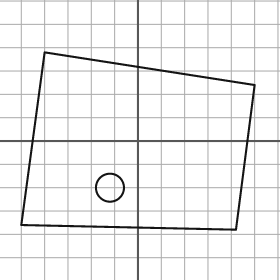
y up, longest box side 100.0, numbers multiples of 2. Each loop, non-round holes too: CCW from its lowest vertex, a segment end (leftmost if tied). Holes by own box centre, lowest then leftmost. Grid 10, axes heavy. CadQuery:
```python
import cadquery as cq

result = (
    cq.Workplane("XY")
    .moveTo(42.0, -38.0)
    .lineTo(50.0, 24.0)
    .lineTo(-40.0, 38.0)
    .lineTo(-50.0, -36.0)
    .close()
    .moveTo(-12.0, -20.0)
    .circle(6.0)
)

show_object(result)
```